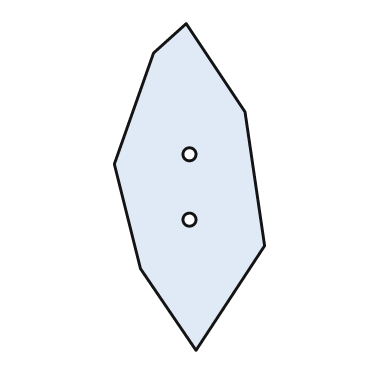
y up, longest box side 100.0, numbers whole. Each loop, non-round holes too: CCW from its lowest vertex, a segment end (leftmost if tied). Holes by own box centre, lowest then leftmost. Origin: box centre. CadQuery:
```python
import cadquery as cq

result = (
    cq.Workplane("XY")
    .moveTo(2.0, -50.0)
    .lineTo(23.0, -18.0)
    .lineTo(17.0, 23.0)
    .lineTo(-1.0, 50.0)
    .lineTo(-11.0, 41.0)
    .lineTo(-23.0, 7.0)
    .lineTo(-15.0, -25.0)
    .close()
    .moveTo(0.0, -10.0)
    .circle(2.0)
    .moveTo(0.0, 10.0)
    .circle(2.0)
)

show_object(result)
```